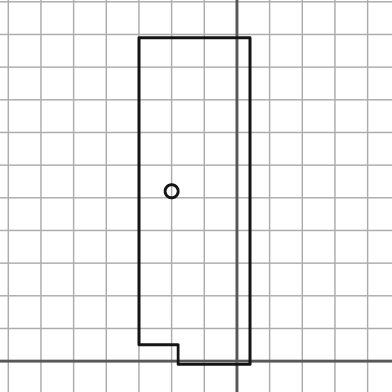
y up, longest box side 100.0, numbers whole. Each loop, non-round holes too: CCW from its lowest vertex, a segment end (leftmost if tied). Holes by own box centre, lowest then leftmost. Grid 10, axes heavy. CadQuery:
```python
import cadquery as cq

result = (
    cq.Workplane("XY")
    .moveTo(-18.0, -1.0)
    .lineTo(4.0, -1.0)
    .lineTo(4.0, 99.0)
    .lineTo(-30.0, 99.0)
    .lineTo(-30.0, 5.0)
    .lineTo(-18.0, 5.0)
    .close()
    .moveTo(-20.0, 52.0)
    .circle(2.0)
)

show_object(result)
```